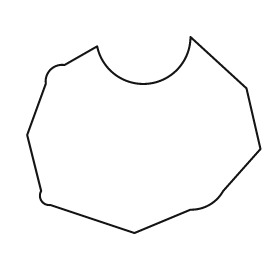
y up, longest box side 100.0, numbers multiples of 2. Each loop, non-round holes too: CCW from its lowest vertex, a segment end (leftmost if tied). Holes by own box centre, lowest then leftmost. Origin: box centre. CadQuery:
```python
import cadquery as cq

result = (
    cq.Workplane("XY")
    .moveTo(-4.0, -42.0)
    .lineTo(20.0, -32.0)
    .threePointArc((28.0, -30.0), (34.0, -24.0))
    .lineTo(50.0, -6.0)
    .lineTo(44.0, 20.0)
    .lineTo(20.0, 42.0)
    .threePointArc((2.0, 22.0), (-20.0, 38.0))
    .lineTo(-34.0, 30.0)
    .threePointArc((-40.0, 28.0), (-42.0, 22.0))
    .lineTo(-50.0, 0.0)
    .lineTo(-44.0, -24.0)
    .threePointArc((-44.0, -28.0), (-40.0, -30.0))
    .close()
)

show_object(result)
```